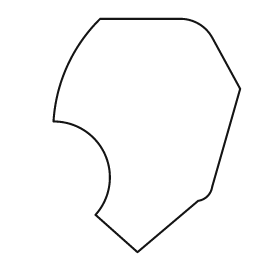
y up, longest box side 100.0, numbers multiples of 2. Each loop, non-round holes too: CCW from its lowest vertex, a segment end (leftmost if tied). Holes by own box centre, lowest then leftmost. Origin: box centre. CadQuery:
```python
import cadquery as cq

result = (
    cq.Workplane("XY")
    .moveTo(-4.0, -50.0)
    .lineTo(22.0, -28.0)
    .threePointArc((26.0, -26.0), (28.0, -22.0))
    .lineTo(40.0, 20.0)
    .lineTo(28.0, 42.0)
    .threePointArc((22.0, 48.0), (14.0, 50.0))
    .lineTo(-20.0, 50.0)
    .threePointArc((-34.0, 30.0), (-40.0, 6.0))
    .threePointArc((-18.0, -8.0), (-22.0, -34.0))
    .close()
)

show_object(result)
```